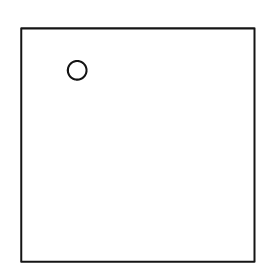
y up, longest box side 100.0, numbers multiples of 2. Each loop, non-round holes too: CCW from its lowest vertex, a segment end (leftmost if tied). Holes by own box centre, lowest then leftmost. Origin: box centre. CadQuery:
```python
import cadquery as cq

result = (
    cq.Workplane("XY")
    .moveTo(-50.0, -50.0)
    .lineTo(50.0, -50.0)
    .lineTo(50.0, 50.0)
    .lineTo(-50.0, 50.0)
    .close()
    .moveTo(-26.0, 32.0)
    .circle(4.0)
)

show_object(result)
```